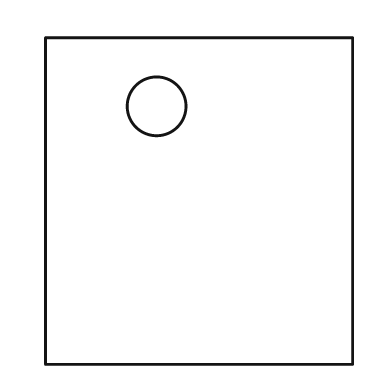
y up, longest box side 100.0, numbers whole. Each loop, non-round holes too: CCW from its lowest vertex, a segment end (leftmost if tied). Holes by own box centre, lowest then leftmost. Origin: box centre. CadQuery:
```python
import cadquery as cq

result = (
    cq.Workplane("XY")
    .moveTo(-47.0, -50.0)
    .lineTo(47.0, -50.0)
    .lineTo(47.0, 50.0)
    .lineTo(-47.0, 50.0)
    .close()
    .moveTo(-13.0, 29.0)
    .circle(9.0)
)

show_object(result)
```